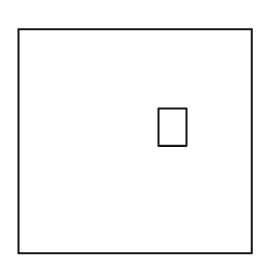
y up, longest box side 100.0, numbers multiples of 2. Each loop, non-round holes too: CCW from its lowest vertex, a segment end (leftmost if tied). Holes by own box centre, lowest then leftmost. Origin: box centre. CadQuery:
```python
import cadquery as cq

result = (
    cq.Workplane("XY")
    .moveTo(-50.0, -48.0)
    .lineTo(50.0, -48.0)
    .lineTo(50.0, 48.0)
    .lineTo(-50.0, 48.0)
    .close()
    .moveTo(10.0, -2.0)
    .lineTo(22.0, -2.0)
    .lineTo(22.0, 14.0)
    .lineTo(10.0, 14.0)
    .close()
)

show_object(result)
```